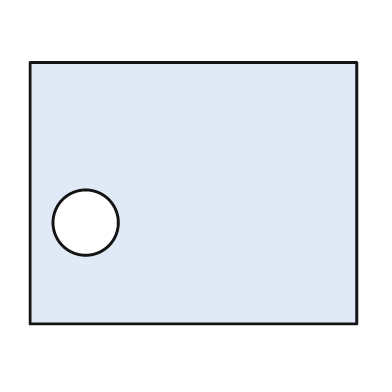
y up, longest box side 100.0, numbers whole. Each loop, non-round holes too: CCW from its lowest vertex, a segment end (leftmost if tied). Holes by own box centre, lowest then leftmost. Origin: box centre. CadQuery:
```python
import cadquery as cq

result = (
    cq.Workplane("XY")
    .moveTo(-50.0, -40.0)
    .lineTo(50.0, -40.0)
    .lineTo(50.0, 40.0)
    .lineTo(-50.0, 40.0)
    .close()
    .moveTo(-33.0, -9.0)
    .circle(10.0)
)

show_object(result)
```